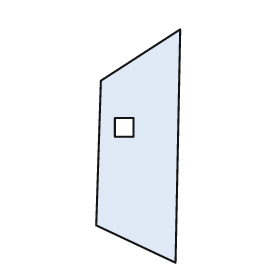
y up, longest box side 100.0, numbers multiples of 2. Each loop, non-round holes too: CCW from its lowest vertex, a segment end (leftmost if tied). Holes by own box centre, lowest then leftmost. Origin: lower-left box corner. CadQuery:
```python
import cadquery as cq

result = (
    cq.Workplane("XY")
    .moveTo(34.0, 0.0)
    .lineTo(36.0, 100.0)
    .lineTo(2.0, 78.0)
    .lineTo(0.0, 16.0)
    .close()
    .moveTo(8.0, 54.0)
    .lineTo(16.0, 54.0)
    .lineTo(16.0, 62.0)
    .lineTo(8.0, 62.0)
    .close()
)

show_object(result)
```